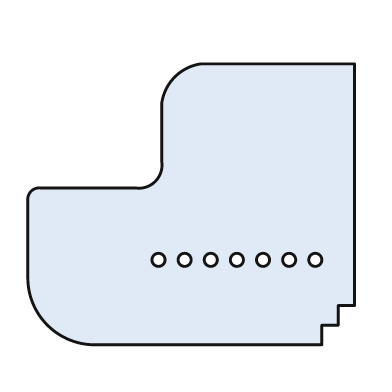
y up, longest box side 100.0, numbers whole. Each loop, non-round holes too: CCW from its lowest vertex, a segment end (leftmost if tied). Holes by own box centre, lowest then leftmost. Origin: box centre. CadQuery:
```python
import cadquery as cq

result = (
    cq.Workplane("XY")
    .moveTo(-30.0, -43.0)
    .lineTo(40.0, -43.0)
    .lineTo(40.0, -37.0)
    .lineTo(45.0, -37.0)
    .lineTo(45.0, -31.0)
    .lineTo(50.0, -31.0)
    .lineTo(50.0, 43.0)
    .lineTo(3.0, 43.0)
    .threePointArc((-5.0, 39.0), (-9.0, 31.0))
    .lineTo(-9.0, 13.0)
    .threePointArc((-11.0, 7.0), (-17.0, 5.0))
    .lineTo(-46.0, 5.0)
    .threePointArc((-49.0, 4.0), (-50.0, 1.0))
    .lineTo(-50.0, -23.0)
    .threePointArc((-44.0, -37.0), (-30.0, -43.0))
    .close()
    .moveTo(-10.0, -17.0)
    .circle(2.0)
    .moveTo(-2.0, -17.0)
    .circle(2.0)
    .moveTo(6.0, -17.0)
    .circle(2.0)
    .moveTo(14.0, -17.0)
    .circle(2.0)
    .moveTo(22.0, -17.0)
    .circle(2.0)
    .moveTo(30.0, -17.0)
    .circle(2.0)
    .moveTo(38.0, -17.0)
    .circle(2.0)
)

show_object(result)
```